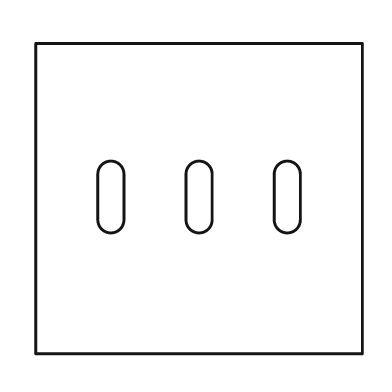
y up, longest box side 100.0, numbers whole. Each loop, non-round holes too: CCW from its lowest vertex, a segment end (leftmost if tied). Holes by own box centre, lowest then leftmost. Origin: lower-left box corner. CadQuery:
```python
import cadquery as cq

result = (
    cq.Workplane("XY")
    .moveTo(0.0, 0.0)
    .lineTo(100.0, 0.0)
    .lineTo(100.0, 95.0)
    .lineTo(0.0, 95.0)
    .close()
    .moveTo(19.0, 41.0)
    .threePointArc((23.0, 37.0), (27.0, 41.0))
    .lineTo(27.0, 55.0)
    .threePointArc((23.0, 59.0), (19.0, 55.0))
    .close()
    .moveTo(46.0, 41.0)
    .threePointArc((50.0, 37.0), (54.0, 41.0))
    .lineTo(54.0, 55.0)
    .threePointArc((50.0, 59.0), (46.0, 55.0))
    .close()
    .moveTo(73.0, 41.0)
    .threePointArc((77.0, 37.0), (81.0, 41.0))
    .lineTo(81.0, 55.0)
    .threePointArc((77.0, 59.0), (73.0, 55.0))
    .close()
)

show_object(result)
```